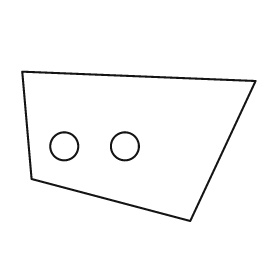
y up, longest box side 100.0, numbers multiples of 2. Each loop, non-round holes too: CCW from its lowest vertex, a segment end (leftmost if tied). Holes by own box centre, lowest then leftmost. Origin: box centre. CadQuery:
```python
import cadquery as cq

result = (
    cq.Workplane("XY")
    .moveTo(22.0, -32.0)
    .lineTo(50.0, 28.0)
    .lineTo(-50.0, 32.0)
    .lineTo(-46.0, -14.0)
    .close()
    .moveTo(-32.0, 0.0)
    .circle(6.0)
    .moveTo(-6.0, 0.0)
    .circle(6.0)
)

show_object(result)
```